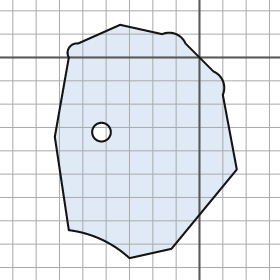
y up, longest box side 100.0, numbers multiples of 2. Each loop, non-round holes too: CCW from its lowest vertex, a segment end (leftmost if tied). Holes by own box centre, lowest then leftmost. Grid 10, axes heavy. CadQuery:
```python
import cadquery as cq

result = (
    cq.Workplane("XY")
    .moveTo(-30.0, -86.0)
    .lineTo(-12.0, -82.0)
    .lineTo(16.0, -48.0)
    .lineTo(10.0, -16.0)
    .threePointArc((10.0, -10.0), (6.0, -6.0))
    .lineTo(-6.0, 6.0)
    .threePointArc((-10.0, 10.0), (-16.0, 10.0))
    .lineTo(-34.0, 14.0)
    .lineTo(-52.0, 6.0)
    .threePointArc((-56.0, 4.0), (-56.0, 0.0))
    .lineTo(-62.0, -34.0)
    .lineTo(-56.0, -74.0)
    .threePointArc((-42.0, -78.0), (-30.0, -86.0))
    .close()
    .moveTo(-42.0, -32.0)
    .circle(4.0)
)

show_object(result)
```